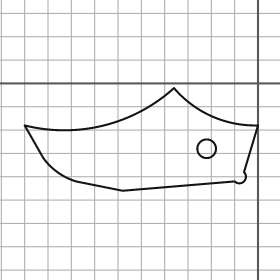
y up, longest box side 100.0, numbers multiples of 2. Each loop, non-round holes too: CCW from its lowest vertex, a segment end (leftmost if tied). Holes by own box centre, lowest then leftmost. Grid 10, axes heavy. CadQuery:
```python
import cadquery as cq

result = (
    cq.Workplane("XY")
    .moveTo(-58.0, -46.0)
    .lineTo(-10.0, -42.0)
    .threePointArc((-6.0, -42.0), (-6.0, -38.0))
    .lineTo(0.0, -18.0)
    .threePointArc((-20.0, -14.0), (-36.0, -2.0))
    .threePointArc((-66.0, -18.0), (-100.0, -18.0))
    .lineTo(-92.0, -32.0)
    .threePointArc((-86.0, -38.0), (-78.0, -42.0))
    .close()
    .moveTo(-22.0, -28.0)
    .circle(4.0)
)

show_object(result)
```